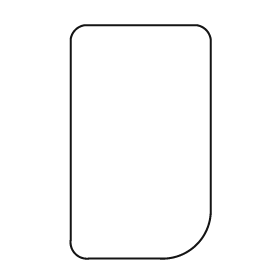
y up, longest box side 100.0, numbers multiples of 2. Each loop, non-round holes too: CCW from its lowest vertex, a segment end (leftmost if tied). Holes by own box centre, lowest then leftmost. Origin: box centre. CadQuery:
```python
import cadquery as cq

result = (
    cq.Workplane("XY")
    .moveTo(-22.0, -50.0)
    .lineTo(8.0, -50.0)
    .threePointArc((24.0, -44.0), (30.0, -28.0))
    .lineTo(30.0, 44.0)
    .threePointArc((28.0, 48.0), (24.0, 50.0))
    .lineTo(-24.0, 50.0)
    .threePointArc((-28.0, 48.0), (-30.0, 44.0))
    .lineTo(-30.0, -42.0)
    .threePointArc((-28.0, -48.0), (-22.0, -50.0))
    .close()
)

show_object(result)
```